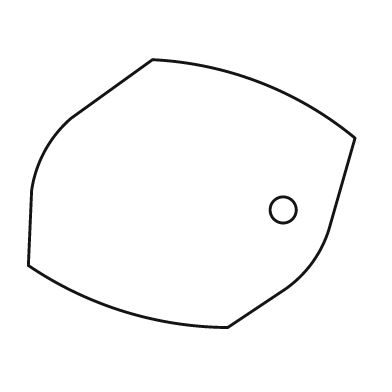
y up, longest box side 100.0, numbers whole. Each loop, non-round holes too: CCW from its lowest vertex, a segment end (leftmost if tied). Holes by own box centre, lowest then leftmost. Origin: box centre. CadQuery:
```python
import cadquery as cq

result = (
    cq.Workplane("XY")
    .moveTo(11.0, -41.0)
    .lineTo(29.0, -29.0)
    .threePointArc((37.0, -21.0), (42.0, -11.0))
    .lineTo(50.0, 17.0)
    .threePointArc((21.0, 34.0), (-12.0, 41.0))
    .lineTo(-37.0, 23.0)
    .threePointArc((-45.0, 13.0), (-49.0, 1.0))
    .lineTo(-50.0, -22.0)
    .threePointArc((-21.0, -36.0), (11.0, -41.0))
    .close()
    .moveTo(28.0, -5.0)
    .circle(4.0)
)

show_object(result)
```